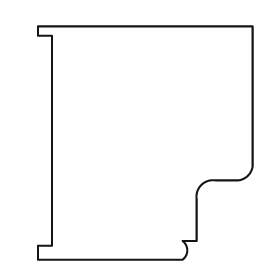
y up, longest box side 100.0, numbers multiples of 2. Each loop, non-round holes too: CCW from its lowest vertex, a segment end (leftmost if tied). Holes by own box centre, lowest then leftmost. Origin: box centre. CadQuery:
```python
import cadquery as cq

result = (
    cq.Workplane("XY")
    .moveTo(-46.0, -50.0)
    .lineTo(16.0, -50.0)
    .threePointArc((18.0, -46.0), (16.0, -42.0))
    .lineTo(22.0, -42.0)
    .lineTo(22.0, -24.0)
    .threePointArc((24.0, -18.0), (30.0, -16.0))
    .lineTo(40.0, -16.0)
    .threePointArc((44.0, -14.0), (46.0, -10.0))
    .lineTo(46.0, 50.0)
    .lineTo(-46.0, 50.0)
    .lineTo(-46.0, 46.0)
    .lineTo(-40.0, 46.0)
    .lineTo(-40.0, -44.0)
    .lineTo(-46.0, -44.0)
    .close()
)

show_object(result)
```